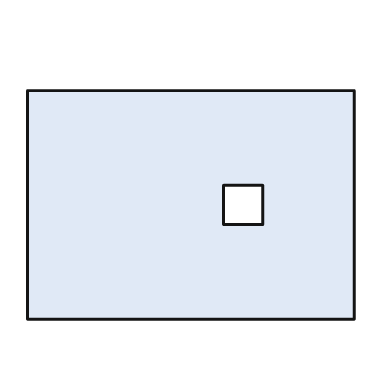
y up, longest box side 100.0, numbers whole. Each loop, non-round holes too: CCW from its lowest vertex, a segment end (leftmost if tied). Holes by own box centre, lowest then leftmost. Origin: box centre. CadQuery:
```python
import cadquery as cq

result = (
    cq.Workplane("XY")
    .moveTo(-50.0, -35.0)
    .lineTo(50.0, -35.0)
    .lineTo(50.0, 35.0)
    .lineTo(-50.0, 35.0)
    .close()
    .moveTo(10.0, -6.0)
    .lineTo(22.0, -6.0)
    .lineTo(22.0, 6.0)
    .lineTo(10.0, 6.0)
    .close()
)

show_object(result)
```